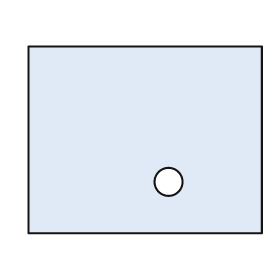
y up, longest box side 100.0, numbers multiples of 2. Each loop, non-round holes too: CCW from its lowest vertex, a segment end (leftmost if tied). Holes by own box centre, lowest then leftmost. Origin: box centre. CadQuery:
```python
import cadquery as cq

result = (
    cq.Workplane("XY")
    .moveTo(-50.0, -40.0)
    .lineTo(50.0, -40.0)
    .lineTo(50.0, 40.0)
    .lineTo(-50.0, 40.0)
    .close()
    .moveTo(10.0, -18.0)
    .circle(6.0)
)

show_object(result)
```